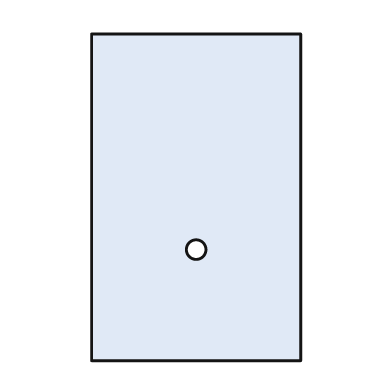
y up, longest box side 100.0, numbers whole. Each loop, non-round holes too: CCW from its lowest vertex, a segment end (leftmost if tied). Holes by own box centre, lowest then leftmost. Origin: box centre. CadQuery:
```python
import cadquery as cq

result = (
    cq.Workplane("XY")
    .moveTo(-32.0, -50.0)
    .lineTo(32.0, -50.0)
    .lineTo(32.0, 50.0)
    .lineTo(-32.0, 50.0)
    .close()
    .moveTo(0.0, -16.0)
    .circle(3.0)
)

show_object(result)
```